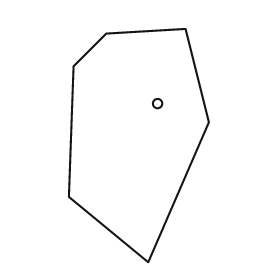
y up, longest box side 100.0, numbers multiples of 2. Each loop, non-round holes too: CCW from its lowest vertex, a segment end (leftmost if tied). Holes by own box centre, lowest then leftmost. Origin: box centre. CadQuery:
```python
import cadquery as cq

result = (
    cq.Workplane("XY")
    .moveTo(4.0, -50.0)
    .lineTo(30.0, 10.0)
    .lineTo(20.0, 50.0)
    .lineTo(-14.0, 48.0)
    .lineTo(-28.0, 34.0)
    .lineTo(-30.0, -22.0)
    .close()
    .moveTo(8.0, 18.0)
    .circle(2.0)
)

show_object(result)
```